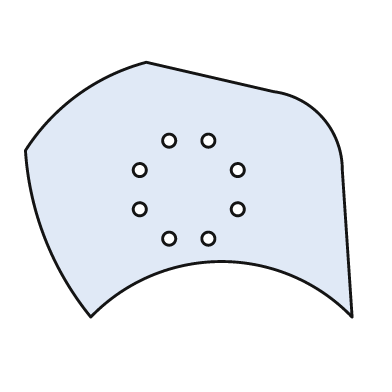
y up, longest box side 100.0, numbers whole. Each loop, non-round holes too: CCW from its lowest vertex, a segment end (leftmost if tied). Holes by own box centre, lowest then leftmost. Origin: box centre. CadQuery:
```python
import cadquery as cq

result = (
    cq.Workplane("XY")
    .moveTo(-30.0, -39.0)
    .threePointArc((10.0, -22.0), (50.0, -39.0))
    .lineTo(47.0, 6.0)
    .threePointArc((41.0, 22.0), (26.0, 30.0))
    .lineTo(-13.0, 39.0)
    .threePointArc((-34.0, 29.0), (-50.0, 12.0))
    .threePointArc((-44.0, -15.0), (-30.0, -39.0))
    .close()
    .moveTo(-6.0, -15.0)
    .circle(2.0)
    .moveTo(6.0, -15.0)
    .circle(2.0)
    .moveTo(-15.0, -6.0)
    .circle(2.0)
    .moveTo(15.0, -6.0)
    .circle(2.0)
    .moveTo(-15.0, 6.0)
    .circle(2.0)
    .moveTo(15.0, 6.0)
    .circle(2.0)
    .moveTo(-6.0, 15.0)
    .circle(2.0)
    .moveTo(6.0, 15.0)
    .circle(2.0)
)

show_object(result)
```